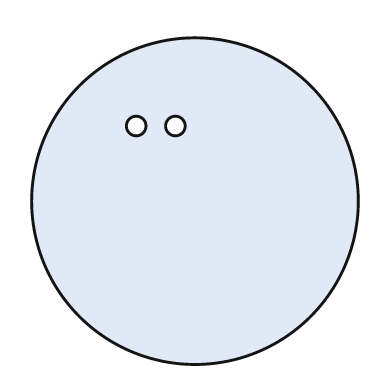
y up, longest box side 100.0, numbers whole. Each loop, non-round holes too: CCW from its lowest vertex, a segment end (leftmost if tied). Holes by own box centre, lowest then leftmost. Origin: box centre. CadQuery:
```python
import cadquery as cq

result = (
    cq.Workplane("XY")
    .moveTo(0.0, 0.0)
    .circle(50.0)
    .moveTo(-18.0, 23.0)
    .circle(3.0)
    .moveTo(-6.0, 23.0)
    .circle(3.0)
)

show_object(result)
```